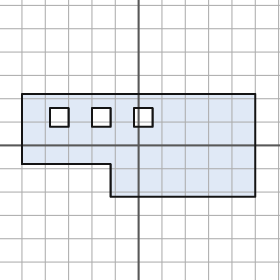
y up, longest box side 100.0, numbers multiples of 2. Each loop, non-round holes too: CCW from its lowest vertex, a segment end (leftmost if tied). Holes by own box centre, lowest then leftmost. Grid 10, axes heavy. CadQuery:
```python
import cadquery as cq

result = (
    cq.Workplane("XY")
    .moveTo(-12.0, -22.0)
    .lineTo(50.0, -22.0)
    .lineTo(50.0, 22.0)
    .lineTo(-50.0, 22.0)
    .lineTo(-50.0, -8.0)
    .lineTo(-12.0, -8.0)
    .close()
    .moveTo(-38.0, 8.0)
    .lineTo(-30.0, 8.0)
    .lineTo(-30.0, 16.0)
    .lineTo(-38.0, 16.0)
    .close()
    .moveTo(-20.0, 8.0)
    .lineTo(-12.0, 8.0)
    .lineTo(-12.0, 16.0)
    .lineTo(-20.0, 16.0)
    .close()
    .moveTo(-2.0, 8.0)
    .lineTo(6.0, 8.0)
    .lineTo(6.0, 16.0)
    .lineTo(-2.0, 16.0)
    .close()
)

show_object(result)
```